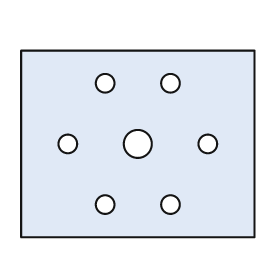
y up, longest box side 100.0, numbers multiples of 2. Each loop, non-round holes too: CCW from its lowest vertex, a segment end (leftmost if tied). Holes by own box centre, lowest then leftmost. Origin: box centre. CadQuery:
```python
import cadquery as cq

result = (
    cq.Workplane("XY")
    .moveTo(-50.0, -40.0)
    .lineTo(50.0, -40.0)
    .lineTo(50.0, 40.0)
    .lineTo(-50.0, 40.0)
    .close()
    .moveTo(-14.0, -26.0)
    .circle(4.0)
    .moveTo(14.0, -26.0)
    .circle(4.0)
    .moveTo(-30.0, 0.0)
    .circle(4.0)
    .moveTo(0.0, 0.0)
    .circle(6.0)
    .moveTo(30.0, 0.0)
    .circle(4.0)
    .moveTo(-14.0, 26.0)
    .circle(4.0)
    .moveTo(14.0, 26.0)
    .circle(4.0)
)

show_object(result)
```